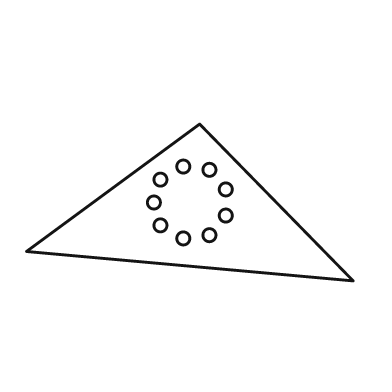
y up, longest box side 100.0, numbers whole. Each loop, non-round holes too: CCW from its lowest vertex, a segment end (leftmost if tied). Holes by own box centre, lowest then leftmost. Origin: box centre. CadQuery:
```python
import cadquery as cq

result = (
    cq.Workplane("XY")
    .moveTo(50.0, -24.0)
    .lineTo(3.0, 24.0)
    .lineTo(-50.0, -15.0)
    .close()
    .moveTo(-2.0, -11.0)
    .circle(2.0)
    .moveTo(6.0, -10.0)
    .circle(2.0)
    .moveTo(-9.0, -7.0)
    .circle(2.0)
    .moveTo(11.0, -4.0)
    .circle(2.0)
    .moveTo(-11.0, 0.0)
    .circle(2.0)
    .moveTo(11.0, 4.0)
    .circle(2.0)
    .moveTo(-9.0, 7.0)
    .circle(2.0)
    .moveTo(6.0, 10.0)
    .circle(2.0)
    .moveTo(-2.0, 11.0)
    .circle(2.0)
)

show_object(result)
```